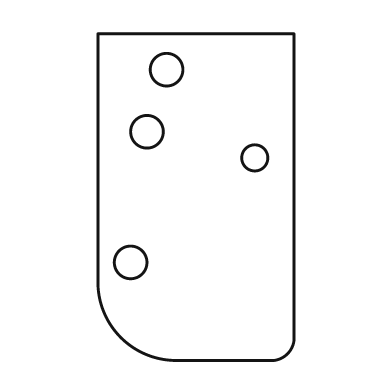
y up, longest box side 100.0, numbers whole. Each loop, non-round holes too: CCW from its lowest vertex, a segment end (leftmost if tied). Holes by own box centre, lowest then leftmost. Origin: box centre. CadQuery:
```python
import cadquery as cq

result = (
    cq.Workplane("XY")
    .moveTo(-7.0, -50.0)
    .lineTo(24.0, -50.0)
    .threePointArc((28.0, -48.0), (30.0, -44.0))
    .lineTo(30.0, 50.0)
    .lineTo(-30.0, 50.0)
    .lineTo(-30.0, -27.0)
    .threePointArc((-23.0, -43.0), (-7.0, -50.0))
    .close()
    .moveTo(-20.0, -20.0)
    .circle(5.0)
    .moveTo(18.0, 12.0)
    .circle(4.0)
    .moveTo(-15.0, 20.0)
    .circle(5.0)
    .moveTo(-9.0, 39.0)
    .circle(5.0)
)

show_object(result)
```